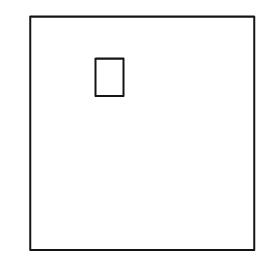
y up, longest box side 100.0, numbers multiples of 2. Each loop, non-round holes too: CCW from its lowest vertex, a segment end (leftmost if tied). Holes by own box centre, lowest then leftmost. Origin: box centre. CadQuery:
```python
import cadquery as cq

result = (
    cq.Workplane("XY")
    .moveTo(-48.0, -50.0)
    .lineTo(48.0, -50.0)
    .lineTo(48.0, 50.0)
    .lineTo(-48.0, 50.0)
    .close()
    .moveTo(-20.0, 16.0)
    .lineTo(-8.0, 16.0)
    .lineTo(-8.0, 32.0)
    .lineTo(-20.0, 32.0)
    .close()
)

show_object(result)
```